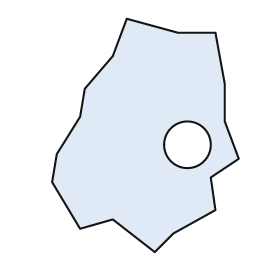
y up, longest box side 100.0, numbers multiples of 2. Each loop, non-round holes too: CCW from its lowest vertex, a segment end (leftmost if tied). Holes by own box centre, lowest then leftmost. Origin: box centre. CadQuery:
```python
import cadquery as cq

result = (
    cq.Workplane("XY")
    .moveTo(4.0, -50.0)
    .lineTo(12.0, -42.0)
    .lineTo(30.0, -32.0)
    .lineTo(28.0, -18.0)
    .lineTo(40.0, -10.0)
    .lineTo(34.0, 6.0)
    .lineTo(34.0, 22.0)
    .lineTo(30.0, 44.0)
    .lineTo(14.0, 44.0)
    .lineTo(-8.0, 50.0)
    .lineTo(-14.0, 34.0)
    .lineTo(-26.0, 20.0)
    .lineTo(-28.0, 8.0)
    .lineTo(-38.0, -8.0)
    .lineTo(-40.0, -20.0)
    .lineTo(-28.0, -40.0)
    .lineTo(-14.0, -36.0)
    .close()
    .moveTo(18.0, -4.0)
    .circle(10.0)
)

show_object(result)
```